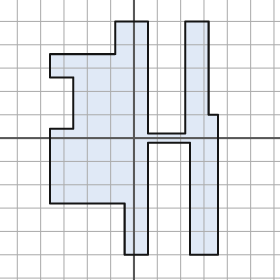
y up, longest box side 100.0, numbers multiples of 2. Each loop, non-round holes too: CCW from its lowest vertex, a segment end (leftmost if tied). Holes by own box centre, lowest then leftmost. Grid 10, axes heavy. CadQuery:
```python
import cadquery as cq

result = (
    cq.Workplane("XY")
    .moveTo(-4.0, -50.0)
    .lineTo(6.0, -50.0)
    .lineTo(6.0, -2.0)
    .lineTo(24.0, -2.0)
    .lineTo(24.0, -50.0)
    .lineTo(36.0, -50.0)
    .lineTo(36.0, 10.0)
    .lineTo(32.0, 10.0)
    .lineTo(32.0, 50.0)
    .lineTo(22.0, 50.0)
    .lineTo(22.0, 2.0)
    .lineTo(6.0, 2.0)
    .lineTo(6.0, 50.0)
    .lineTo(-8.0, 50.0)
    .lineTo(-8.0, 36.0)
    .lineTo(-36.0, 36.0)
    .lineTo(-36.0, 26.0)
    .lineTo(-26.0, 26.0)
    .lineTo(-26.0, 4.0)
    .lineTo(-36.0, 4.0)
    .lineTo(-36.0, -28.0)
    .lineTo(-4.0, -28.0)
    .close()
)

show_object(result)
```